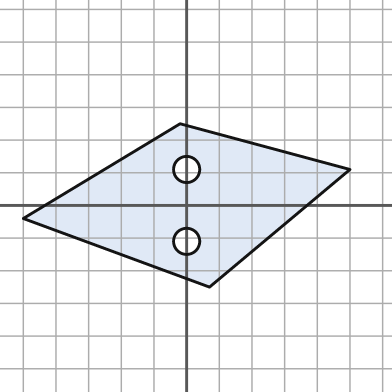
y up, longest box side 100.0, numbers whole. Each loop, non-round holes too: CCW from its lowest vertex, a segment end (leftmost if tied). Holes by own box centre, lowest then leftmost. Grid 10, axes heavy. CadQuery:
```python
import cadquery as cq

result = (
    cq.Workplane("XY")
    .moveTo(7.0, -25.0)
    .lineTo(50.0, 11.0)
    .lineTo(-2.0, 25.0)
    .lineTo(-50.0, -4.0)
    .close()
    .moveTo(0.0, -11.0)
    .circle(4.0)
    .moveTo(0.0, 11.0)
    .circle(4.0)
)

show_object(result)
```